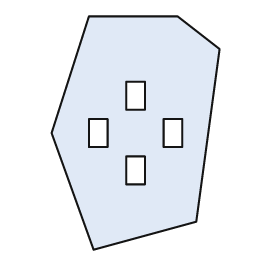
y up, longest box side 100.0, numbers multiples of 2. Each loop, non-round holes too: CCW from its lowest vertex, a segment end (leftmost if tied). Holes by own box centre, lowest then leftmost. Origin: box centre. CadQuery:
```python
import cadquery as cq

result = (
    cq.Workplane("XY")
    .moveTo(-18.0, -50.0)
    .lineTo(26.0, -38.0)
    .lineTo(36.0, 36.0)
    .lineTo(18.0, 50.0)
    .lineTo(-20.0, 50.0)
    .lineTo(-36.0, 0.0)
    .close()
    .moveTo(-4.0, -22.0)
    .lineTo(4.0, -22.0)
    .lineTo(4.0, -10.0)
    .lineTo(-4.0, -10.0)
    .close()
    .moveTo(-20.0, -6.0)
    .lineTo(-12.0, -6.0)
    .lineTo(-12.0, 6.0)
    .lineTo(-20.0, 6.0)
    .close()
    .moveTo(12.0, -6.0)
    .lineTo(20.0, -6.0)
    .lineTo(20.0, 6.0)
    .lineTo(12.0, 6.0)
    .close()
    .moveTo(-4.0, 10.0)
    .lineTo(4.0, 10.0)
    .lineTo(4.0, 22.0)
    .lineTo(-4.0, 22.0)
    .close()
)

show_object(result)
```